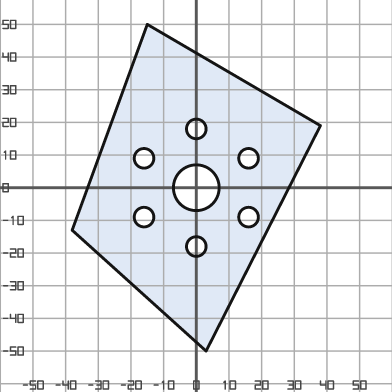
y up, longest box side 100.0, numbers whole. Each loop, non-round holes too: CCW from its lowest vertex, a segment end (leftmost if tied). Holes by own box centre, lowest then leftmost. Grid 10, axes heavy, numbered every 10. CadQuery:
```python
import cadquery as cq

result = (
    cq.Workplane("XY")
    .moveTo(3.0, -50.0)
    .lineTo(38.0, 19.0)
    .lineTo(-15.0, 50.0)
    .lineTo(-38.0, -13.0)
    .close()
    .moveTo(0.0, -18.0)
    .circle(3.0)
    .moveTo(-16.0, -9.0)
    .circle(3.0)
    .moveTo(16.0, -9.0)
    .circle(3.0)
    .moveTo(0.0, 0.0)
    .circle(7.0)
    .moveTo(-16.0, 9.0)
    .circle(3.0)
    .moveTo(16.0, 9.0)
    .circle(3.0)
    .moveTo(0.0, 18.0)
    .circle(3.0)
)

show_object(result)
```